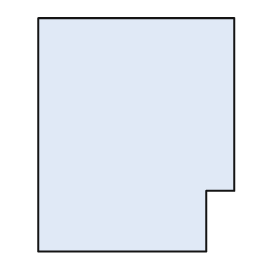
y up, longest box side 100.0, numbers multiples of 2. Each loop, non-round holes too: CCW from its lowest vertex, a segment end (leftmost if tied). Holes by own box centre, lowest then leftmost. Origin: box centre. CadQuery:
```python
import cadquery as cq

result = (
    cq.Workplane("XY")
    .moveTo(-42.0, -50.0)
    .lineTo(30.0, -50.0)
    .lineTo(30.0, -24.0)
    .lineTo(42.0, -24.0)
    .lineTo(42.0, 50.0)
    .lineTo(-42.0, 50.0)
    .close()
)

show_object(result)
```